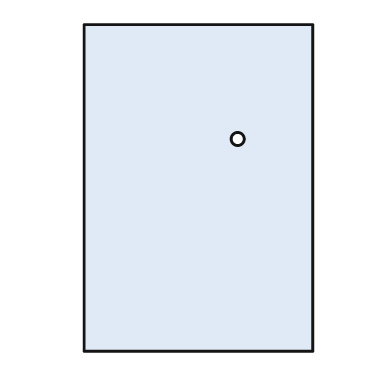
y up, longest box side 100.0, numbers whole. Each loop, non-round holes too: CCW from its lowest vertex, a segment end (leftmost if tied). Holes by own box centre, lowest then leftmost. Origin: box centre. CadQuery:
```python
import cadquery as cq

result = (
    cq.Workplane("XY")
    .moveTo(-35.0, -50.0)
    .lineTo(35.0, -50.0)
    .lineTo(35.0, 50.0)
    .lineTo(-35.0, 50.0)
    .close()
    .moveTo(12.0, 15.0)
    .circle(2.0)
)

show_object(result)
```